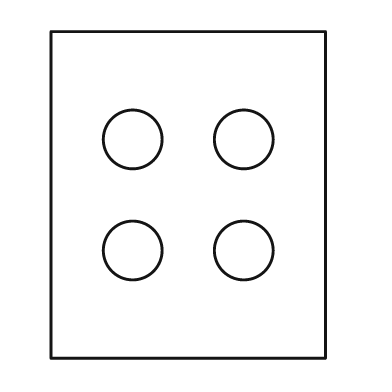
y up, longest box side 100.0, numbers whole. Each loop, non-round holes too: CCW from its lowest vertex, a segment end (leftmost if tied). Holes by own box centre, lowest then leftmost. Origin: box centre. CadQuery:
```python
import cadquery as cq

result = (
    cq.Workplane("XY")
    .moveTo(-42.0, -50.0)
    .lineTo(42.0, -50.0)
    .lineTo(42.0, 50.0)
    .lineTo(-42.0, 50.0)
    .close()
    .moveTo(-17.0, -17.0)
    .circle(9.0)
    .moveTo(17.0, -17.0)
    .circle(9.0)
    .moveTo(-17.0, 17.0)
    .circle(9.0)
    .moveTo(17.0, 17.0)
    .circle(9.0)
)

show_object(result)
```